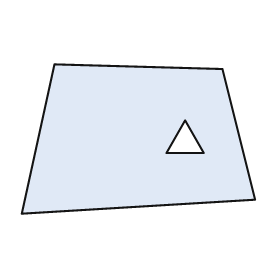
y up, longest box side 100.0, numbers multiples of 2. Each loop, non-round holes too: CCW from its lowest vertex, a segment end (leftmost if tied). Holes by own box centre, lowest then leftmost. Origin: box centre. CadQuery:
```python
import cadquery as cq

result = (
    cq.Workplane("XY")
    .moveTo(-50.0, -32.0)
    .lineTo(50.0, -26.0)
    .lineTo(36.0, 30.0)
    .lineTo(-36.0, 32.0)
    .close()
    .moveTo(12.0, -6.0)
    .lineTo(28.0, -6.0)
    .lineTo(20.0, 8.0)
    .close()
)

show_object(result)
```